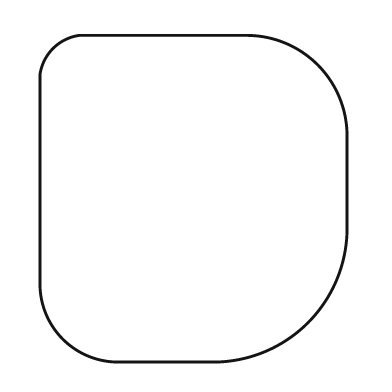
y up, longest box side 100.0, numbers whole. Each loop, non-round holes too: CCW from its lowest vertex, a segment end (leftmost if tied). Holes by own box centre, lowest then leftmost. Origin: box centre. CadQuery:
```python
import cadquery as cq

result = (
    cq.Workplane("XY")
    .moveTo(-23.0, -50.0)
    .lineTo(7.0, -50.0)
    .threePointArc((35.0, -38.0), (47.0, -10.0))
    .lineTo(47.0, 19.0)
    .threePointArc((38.0, 41.0), (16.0, 50.0))
    .lineTo(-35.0, 50.0)
    .threePointArc((-43.0, 46.0), (-47.0, 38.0))
    .lineTo(-47.0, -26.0)
    .threePointArc((-40.0, -43.0), (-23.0, -50.0))
    .close()
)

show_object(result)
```